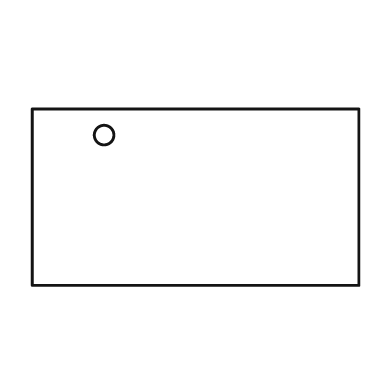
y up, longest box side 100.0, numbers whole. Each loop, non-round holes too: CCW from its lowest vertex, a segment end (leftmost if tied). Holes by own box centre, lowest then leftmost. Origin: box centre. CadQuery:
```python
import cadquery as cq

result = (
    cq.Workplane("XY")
    .moveTo(-50.0, -27.0)
    .lineTo(50.0, -27.0)
    .lineTo(50.0, 27.0)
    .lineTo(-50.0, 27.0)
    .close()
    .moveTo(-28.0, 19.0)
    .circle(3.0)
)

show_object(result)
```